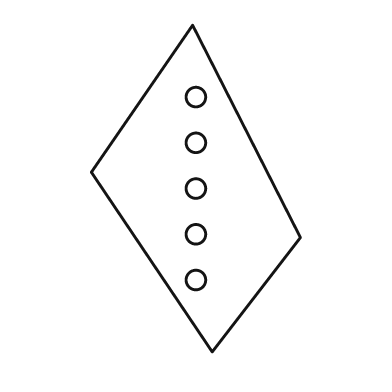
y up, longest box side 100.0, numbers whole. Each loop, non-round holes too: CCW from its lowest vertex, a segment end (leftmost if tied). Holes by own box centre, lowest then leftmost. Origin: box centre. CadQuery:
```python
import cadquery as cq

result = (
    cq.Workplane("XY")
    .moveTo(5.0, -50.0)
    .lineTo(32.0, -15.0)
    .lineTo(-1.0, 50.0)
    .lineTo(-32.0, 5.0)
    .close()
    .moveTo(0.0, -28.0)
    .circle(3.0)
    .moveTo(0.0, -14.0)
    .circle(3.0)
    .moveTo(0.0, 0.0)
    .circle(3.0)
    .moveTo(0.0, 14.0)
    .circle(3.0)
    .moveTo(0.0, 28.0)
    .circle(3.0)
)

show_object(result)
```